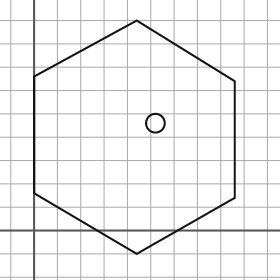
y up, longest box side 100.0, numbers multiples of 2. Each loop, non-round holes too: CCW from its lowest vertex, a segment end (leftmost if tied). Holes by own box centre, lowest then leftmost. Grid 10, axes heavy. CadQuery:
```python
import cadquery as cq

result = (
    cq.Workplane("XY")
    .moveTo(44.0, -10.0)
    .lineTo(86.0, 14.0)
    .lineTo(86.0, 64.0)
    .lineTo(44.0, 90.0)
    .lineTo(0.0, 66.0)
    .lineTo(0.0, 16.0)
    .close()
    .moveTo(52.0, 46.0)
    .circle(4.0)
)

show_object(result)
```